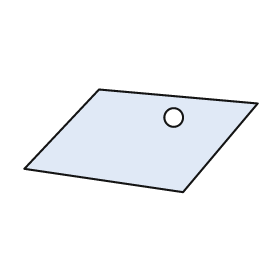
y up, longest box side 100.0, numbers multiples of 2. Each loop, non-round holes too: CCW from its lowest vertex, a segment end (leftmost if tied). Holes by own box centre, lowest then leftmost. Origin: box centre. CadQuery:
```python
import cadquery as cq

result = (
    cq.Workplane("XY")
    .moveTo(18.0, -22.0)
    .lineTo(50.0, 16.0)
    .lineTo(-18.0, 22.0)
    .lineTo(-50.0, -12.0)
    .close()
    .moveTo(14.0, 10.0)
    .circle(4.0)
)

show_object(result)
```